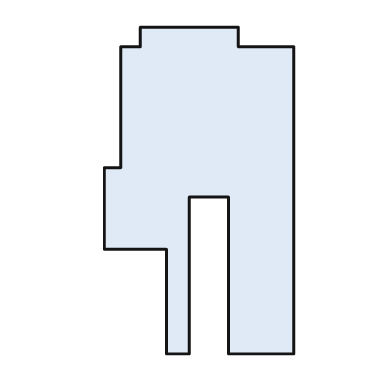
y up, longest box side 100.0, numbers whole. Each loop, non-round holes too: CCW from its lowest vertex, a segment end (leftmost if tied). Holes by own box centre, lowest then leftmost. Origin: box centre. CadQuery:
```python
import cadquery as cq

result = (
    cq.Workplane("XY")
    .moveTo(-10.0, -50.0)
    .lineTo(-3.0, -50.0)
    .lineTo(-3.0, -2.0)
    .lineTo(9.0, -2.0)
    .lineTo(9.0, -50.0)
    .lineTo(29.0, -50.0)
    .lineTo(29.0, 44.0)
    .lineTo(12.0, 44.0)
    .lineTo(12.0, 50.0)
    .lineTo(-18.0, 50.0)
    .lineTo(-18.0, 44.0)
    .lineTo(-24.0, 44.0)
    .lineTo(-24.0, 7.0)
    .lineTo(-29.0, 7.0)
    .lineTo(-29.0, -18.0)
    .lineTo(-10.0, -18.0)
    .close()
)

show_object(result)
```